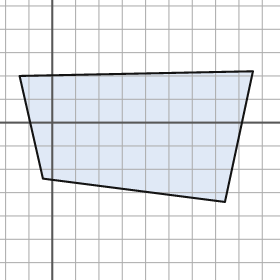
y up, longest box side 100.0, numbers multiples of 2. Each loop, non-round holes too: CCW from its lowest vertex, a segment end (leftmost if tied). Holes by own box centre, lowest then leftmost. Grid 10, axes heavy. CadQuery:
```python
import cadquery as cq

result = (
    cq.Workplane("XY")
    .moveTo(74.0, -34.0)
    .lineTo(86.0, 22.0)
    .lineTo(-14.0, 20.0)
    .lineTo(-4.0, -24.0)
    .close()
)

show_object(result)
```